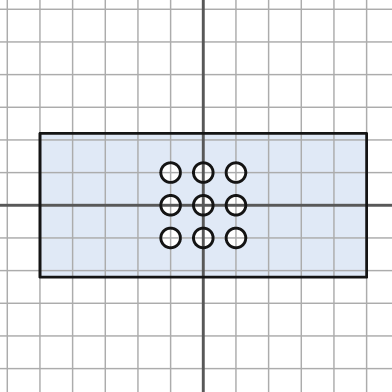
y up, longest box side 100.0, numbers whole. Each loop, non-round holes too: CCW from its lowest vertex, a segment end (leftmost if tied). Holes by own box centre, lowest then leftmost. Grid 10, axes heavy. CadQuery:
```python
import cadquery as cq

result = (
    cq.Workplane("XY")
    .moveTo(-50.0, -22.0)
    .lineTo(50.0, -22.0)
    .lineTo(50.0, 22.0)
    .lineTo(-50.0, 22.0)
    .close()
    .moveTo(-10.0, -10.0)
    .circle(3.0)
    .moveTo(0.0, -10.0)
    .circle(3.0)
    .moveTo(10.0, -10.0)
    .circle(3.0)
    .moveTo(-10.0, 0.0)
    .circle(3.0)
    .moveTo(0.0, 0.0)
    .circle(3.0)
    .moveTo(10.0, 0.0)
    .circle(3.0)
    .moveTo(-10.0, 10.0)
    .circle(3.0)
    .moveTo(0.0, 10.0)
    .circle(3.0)
    .moveTo(10.0, 10.0)
    .circle(3.0)
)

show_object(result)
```